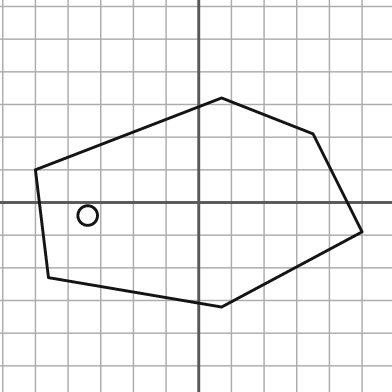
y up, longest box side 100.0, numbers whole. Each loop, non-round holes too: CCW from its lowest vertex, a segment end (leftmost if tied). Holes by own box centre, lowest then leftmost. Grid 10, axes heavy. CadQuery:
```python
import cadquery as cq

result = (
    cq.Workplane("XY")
    .moveTo(7.0, -32.0)
    .lineTo(50.0, -9.0)
    .lineTo(35.0, 21.0)
    .lineTo(7.0, 32.0)
    .lineTo(-50.0, 10.0)
    .lineTo(-46.0, -23.0)
    .close()
    .moveTo(-34.0, -4.0)
    .circle(3.0)
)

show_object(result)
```